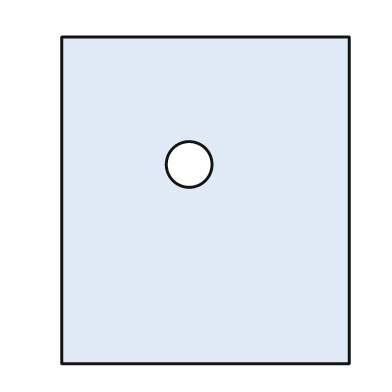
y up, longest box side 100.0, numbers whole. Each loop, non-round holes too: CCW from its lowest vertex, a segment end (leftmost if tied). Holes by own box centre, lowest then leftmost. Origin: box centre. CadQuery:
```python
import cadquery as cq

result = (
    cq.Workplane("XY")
    .moveTo(-44.0, -50.0)
    .lineTo(44.0, -50.0)
    .lineTo(44.0, 50.0)
    .lineTo(-44.0, 50.0)
    .close()
    .moveTo(-5.0, 11.0)
    .circle(7.0)
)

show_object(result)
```